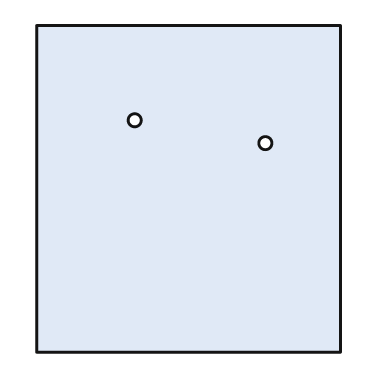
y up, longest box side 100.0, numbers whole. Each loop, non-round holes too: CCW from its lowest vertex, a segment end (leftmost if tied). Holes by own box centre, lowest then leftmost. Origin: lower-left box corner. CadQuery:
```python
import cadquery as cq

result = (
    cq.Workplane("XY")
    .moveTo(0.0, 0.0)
    .lineTo(93.0, 0.0)
    .lineTo(93.0, 100.0)
    .lineTo(0.0, 100.0)
    .close()
    .moveTo(70.0, 64.0)
    .circle(2.0)
    .moveTo(30.0, 71.0)
    .circle(2.0)
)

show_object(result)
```